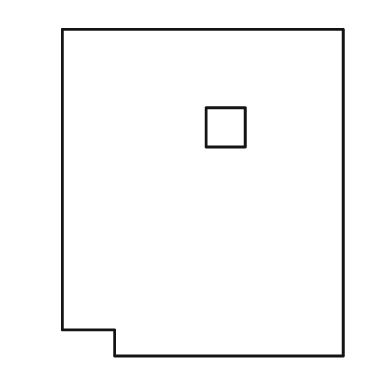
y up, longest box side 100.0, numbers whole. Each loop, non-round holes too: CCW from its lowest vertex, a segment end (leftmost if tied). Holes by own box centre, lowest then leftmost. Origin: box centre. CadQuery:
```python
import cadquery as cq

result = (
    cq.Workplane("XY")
    .moveTo(-27.0, -50.0)
    .lineTo(43.0, -50.0)
    .lineTo(43.0, 50.0)
    .lineTo(-43.0, 50.0)
    .lineTo(-43.0, -42.0)
    .lineTo(-27.0, -42.0)
    .close()
    .moveTo(1.0, 14.0)
    .lineTo(13.0, 14.0)
    .lineTo(13.0, 26.0)
    .lineTo(1.0, 26.0)
    .close()
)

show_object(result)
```